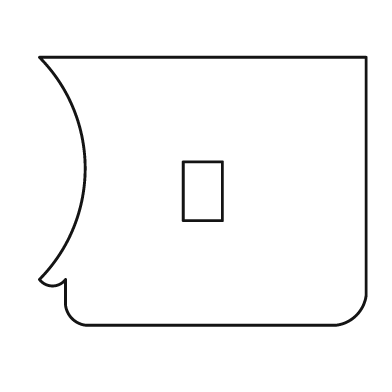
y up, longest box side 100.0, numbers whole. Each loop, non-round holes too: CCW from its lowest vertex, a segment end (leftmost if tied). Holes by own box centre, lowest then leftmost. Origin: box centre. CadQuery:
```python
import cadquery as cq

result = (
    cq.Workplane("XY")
    .moveTo(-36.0, -41.0)
    .lineTo(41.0, -41.0)
    .threePointArc((47.0, -38.0), (50.0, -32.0))
    .lineTo(50.0, 41.0)
    .lineTo(-50.0, 41.0)
    .threePointArc((-36.0, 7.0), (-50.0, -27.0))
    .threePointArc((-46.0, -29.0), (-42.0, -27.0))
    .lineTo(-42.0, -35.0)
    .threePointArc((-40.0, -39.0), (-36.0, -41.0))
    .close()
    .moveTo(-6.0, -9.0)
    .lineTo(6.0, -9.0)
    .lineTo(6.0, 9.0)
    .lineTo(-6.0, 9.0)
    .close()
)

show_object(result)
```